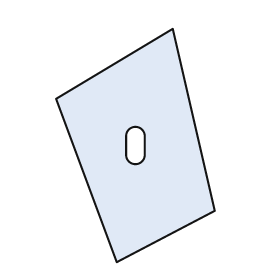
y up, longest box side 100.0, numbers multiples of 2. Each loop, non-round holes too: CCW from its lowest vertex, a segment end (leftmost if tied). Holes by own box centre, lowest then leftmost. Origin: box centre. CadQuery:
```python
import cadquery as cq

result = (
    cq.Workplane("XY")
    .moveTo(-8.0, -50.0)
    .lineTo(34.0, -28.0)
    .lineTo(16.0, 50.0)
    .lineTo(-34.0, 20.0)
    .close()
    .moveTo(-4.0, -4.0)
    .threePointArc((0.0, -8.0), (4.0, -4.0))
    .lineTo(4.0, 4.0)
    .threePointArc((0.0, 8.0), (-4.0, 4.0))
    .close()
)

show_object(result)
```